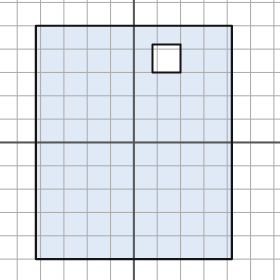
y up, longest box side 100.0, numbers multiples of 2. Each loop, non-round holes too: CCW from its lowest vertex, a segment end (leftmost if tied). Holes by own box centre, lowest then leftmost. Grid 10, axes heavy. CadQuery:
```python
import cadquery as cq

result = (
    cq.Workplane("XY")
    .moveTo(-42.0, -50.0)
    .lineTo(42.0, -50.0)
    .lineTo(42.0, 50.0)
    .lineTo(-42.0, 50.0)
    .close()
    .moveTo(8.0, 30.0)
    .lineTo(20.0, 30.0)
    .lineTo(20.0, 42.0)
    .lineTo(8.0, 42.0)
    .close()
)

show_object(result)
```